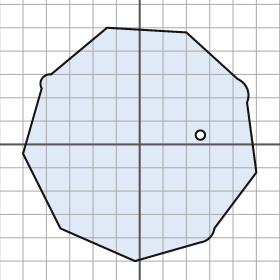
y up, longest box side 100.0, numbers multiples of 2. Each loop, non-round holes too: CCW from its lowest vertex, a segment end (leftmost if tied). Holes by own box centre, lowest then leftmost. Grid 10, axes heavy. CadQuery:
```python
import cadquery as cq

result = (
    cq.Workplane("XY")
    .moveTo(-2.0, -50.0)
    .lineTo(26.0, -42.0)
    .threePointArc((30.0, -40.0), (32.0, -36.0))
    .lineTo(50.0, -12.0)
    .lineTo(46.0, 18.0)
    .threePointArc((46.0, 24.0), (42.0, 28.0))
    .lineTo(20.0, 48.0)
    .lineTo(-14.0, 50.0)
    .lineTo(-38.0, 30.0)
    .threePointArc((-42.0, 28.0), (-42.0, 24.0))
    .lineTo(-50.0, -4.0)
    .lineTo(-34.0, -36.0)
    .close()
    .moveTo(26.0, 4.0)
    .circle(2.0)
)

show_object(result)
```